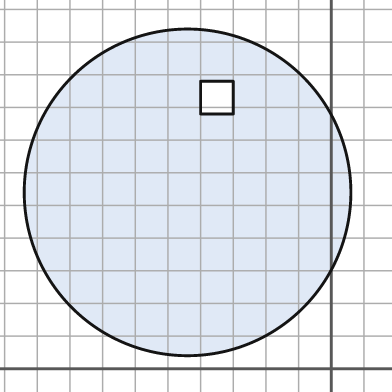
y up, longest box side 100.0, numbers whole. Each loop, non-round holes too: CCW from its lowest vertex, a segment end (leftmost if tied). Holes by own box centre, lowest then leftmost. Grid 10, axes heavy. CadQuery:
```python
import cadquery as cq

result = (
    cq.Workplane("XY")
    .moveTo(-44.0, 54.0)
    .circle(50.0)
    .moveTo(-40.0, 78.0)
    .lineTo(-30.0, 78.0)
    .lineTo(-30.0, 88.0)
    .lineTo(-40.0, 88.0)
    .close()
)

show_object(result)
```